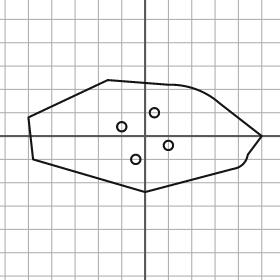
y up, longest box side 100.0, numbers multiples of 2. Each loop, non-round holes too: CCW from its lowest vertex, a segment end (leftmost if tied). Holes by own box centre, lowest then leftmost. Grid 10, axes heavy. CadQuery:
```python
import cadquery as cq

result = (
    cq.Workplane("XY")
    .moveTo(0.0, -24.0)
    .lineTo(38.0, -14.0)
    .threePointArc((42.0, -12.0), (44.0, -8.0))
    .lineTo(50.0, 0.0)
    .lineTo(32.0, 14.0)
    .threePointArc((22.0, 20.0), (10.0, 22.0))
    .lineTo(-16.0, 24.0)
    .lineTo(-50.0, 8.0)
    .lineTo(-48.0, -10.0)
    .close()
    .moveTo(-4.0, -10.0)
    .circle(2.0)
    .moveTo(10.0, -4.0)
    .circle(2.0)
    .moveTo(-10.0, 4.0)
    .circle(2.0)
    .moveTo(4.0, 10.0)
    .circle(2.0)
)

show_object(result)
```